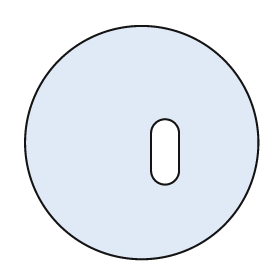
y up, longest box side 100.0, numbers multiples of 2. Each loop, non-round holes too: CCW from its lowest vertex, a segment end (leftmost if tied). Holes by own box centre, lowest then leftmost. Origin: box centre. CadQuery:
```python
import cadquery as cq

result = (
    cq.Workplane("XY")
    .moveTo(0.0, 0.0)
    .circle(50.0)
    .moveTo(4.0, -12.0)
    .threePointArc((10.0, -18.0), (16.0, -12.0))
    .lineTo(16.0, 4.0)
    .threePointArc((10.0, 10.0), (4.0, 4.0))
    .close()
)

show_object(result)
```